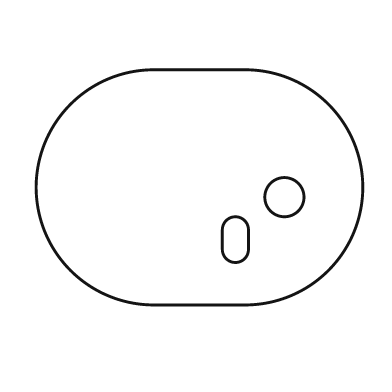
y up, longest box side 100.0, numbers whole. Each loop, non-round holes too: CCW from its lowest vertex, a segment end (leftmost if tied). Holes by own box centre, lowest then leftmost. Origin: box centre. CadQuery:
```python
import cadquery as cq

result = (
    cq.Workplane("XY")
    .moveTo(-14.0, -36.0)
    .lineTo(14.0, -36.0)
    .threePointArc((50.0, 0.0), (14.0, 36.0))
    .lineTo(-14.0, 36.0)
    .threePointArc((-50.0, 0.0), (-14.0, -36.0))
    .close()
    .moveTo(7.0, -19.0)
    .threePointArc((11.0, -23.0), (15.0, -19.0))
    .lineTo(15.0, -13.0)
    .threePointArc((11.0, -9.0), (7.0, -13.0))
    .close()
    .moveTo(26.0, -3.0)
    .circle(6.0)
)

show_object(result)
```